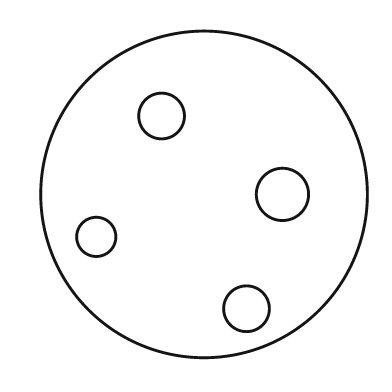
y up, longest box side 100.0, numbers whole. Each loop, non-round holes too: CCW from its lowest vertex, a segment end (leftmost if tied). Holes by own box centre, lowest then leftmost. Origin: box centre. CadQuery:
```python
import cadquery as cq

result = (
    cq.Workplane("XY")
    .moveTo(0.0, 0.0)
    .circle(50.0)
    .moveTo(13.0, -35.0)
    .circle(7.0)
    .moveTo(-33.0, -13.0)
    .circle(6.0)
    .moveTo(24.0, 0.0)
    .circle(8.0)
    .moveTo(-13.0, 24.0)
    .circle(7.0)
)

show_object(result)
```